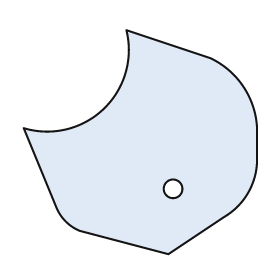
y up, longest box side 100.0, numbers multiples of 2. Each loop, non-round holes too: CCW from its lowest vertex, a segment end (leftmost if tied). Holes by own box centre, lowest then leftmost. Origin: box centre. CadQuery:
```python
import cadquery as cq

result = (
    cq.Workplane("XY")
    .moveTo(12.0, -48.0)
    .lineTo(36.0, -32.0)
    .threePointArc((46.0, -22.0), (50.0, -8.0))
    .lineTo(50.0, 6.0)
    .threePointArc((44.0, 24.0), (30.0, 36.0))
    .lineTo(-6.0, 48.0)
    .threePointArc((-16.0, 14.0), (-50.0, 6.0))
    .lineTo(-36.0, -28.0)
    .threePointArc((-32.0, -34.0), (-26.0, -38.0))
    .close()
    .moveTo(14.0, -20.0)
    .circle(4.0)
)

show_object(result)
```